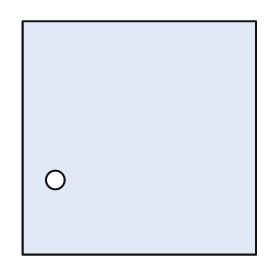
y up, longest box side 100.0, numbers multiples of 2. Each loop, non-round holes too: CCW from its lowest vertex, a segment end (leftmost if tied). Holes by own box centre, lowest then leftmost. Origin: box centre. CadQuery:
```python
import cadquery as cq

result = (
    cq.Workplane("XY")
    .moveTo(-50.0, -50.0)
    .lineTo(50.0, -50.0)
    .lineTo(50.0, 50.0)
    .lineTo(-50.0, 50.0)
    .close()
    .moveTo(-36.0, -18.0)
    .circle(4.0)
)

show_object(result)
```